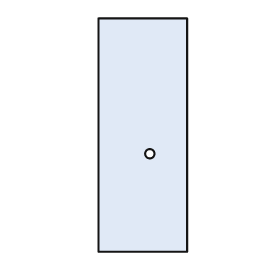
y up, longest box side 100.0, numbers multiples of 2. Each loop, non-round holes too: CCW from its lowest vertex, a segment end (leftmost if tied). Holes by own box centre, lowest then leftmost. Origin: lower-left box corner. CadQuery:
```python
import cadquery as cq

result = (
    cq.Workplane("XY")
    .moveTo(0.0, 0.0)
    .lineTo(38.0, 0.0)
    .lineTo(38.0, 100.0)
    .lineTo(0.0, 100.0)
    .close()
    .moveTo(22.0, 42.0)
    .circle(2.0)
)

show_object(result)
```